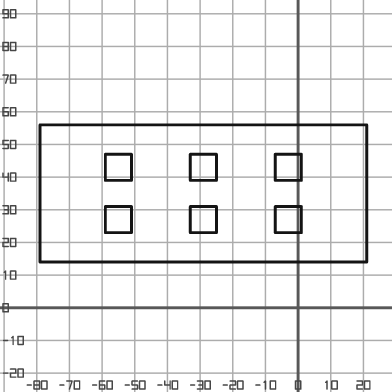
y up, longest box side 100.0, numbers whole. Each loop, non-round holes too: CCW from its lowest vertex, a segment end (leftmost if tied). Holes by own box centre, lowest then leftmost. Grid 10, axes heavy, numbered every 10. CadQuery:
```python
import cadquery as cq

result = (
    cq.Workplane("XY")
    .moveTo(-79.0, 14.0)
    .lineTo(21.0, 14.0)
    .lineTo(21.0, 56.0)
    .lineTo(-79.0, 56.0)
    .close()
    .moveTo(-59.0, 23.0)
    .lineTo(-51.0, 23.0)
    .lineTo(-51.0, 31.0)
    .lineTo(-59.0, 31.0)
    .close()
    .moveTo(-33.0, 23.0)
    .lineTo(-25.0, 23.0)
    .lineTo(-25.0, 31.0)
    .lineTo(-33.0, 31.0)
    .close()
    .moveTo(-7.0, 23.0)
    .lineTo(1.0, 23.0)
    .lineTo(1.0, 31.0)
    .lineTo(-7.0, 31.0)
    .close()
    .moveTo(-59.0, 39.0)
    .lineTo(-51.0, 39.0)
    .lineTo(-51.0, 47.0)
    .lineTo(-59.0, 47.0)
    .close()
    .moveTo(-33.0, 39.0)
    .lineTo(-25.0, 39.0)
    .lineTo(-25.0, 47.0)
    .lineTo(-33.0, 47.0)
    .close()
    .moveTo(-7.0, 39.0)
    .lineTo(1.0, 39.0)
    .lineTo(1.0, 47.0)
    .lineTo(-7.0, 47.0)
    .close()
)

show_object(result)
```